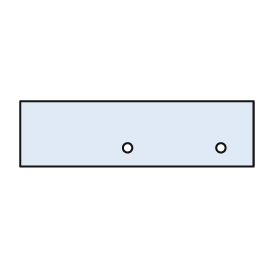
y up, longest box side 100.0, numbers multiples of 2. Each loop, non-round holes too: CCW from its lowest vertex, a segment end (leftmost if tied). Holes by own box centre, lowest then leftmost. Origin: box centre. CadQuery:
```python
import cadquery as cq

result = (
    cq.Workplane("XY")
    .moveTo(-50.0, -14.0)
    .lineTo(50.0, -14.0)
    .lineTo(50.0, 14.0)
    .lineTo(-50.0, 14.0)
    .close()
    .moveTo(-4.0, -6.0)
    .circle(2.0)
    .moveTo(36.0, -6.0)
    .circle(2.0)
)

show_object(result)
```